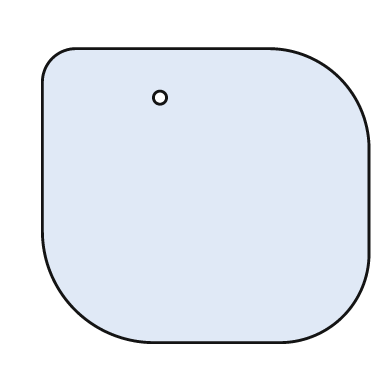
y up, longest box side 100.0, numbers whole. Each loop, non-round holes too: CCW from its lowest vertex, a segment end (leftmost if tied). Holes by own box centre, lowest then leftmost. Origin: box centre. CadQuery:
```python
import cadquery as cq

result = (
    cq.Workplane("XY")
    .moveTo(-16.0, -45.0)
    .lineTo(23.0, -45.0)
    .threePointArc((42.0, -37.0), (50.0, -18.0))
    .lineTo(50.0, 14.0)
    .threePointArc((41.0, 36.0), (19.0, 45.0))
    .lineTo(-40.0, 45.0)
    .threePointArc((-47.0, 42.0), (-50.0, 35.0))
    .lineTo(-50.0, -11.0)
    .threePointArc((-40.0, -35.0), (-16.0, -45.0))
    .close()
    .moveTo(-14.0, 30.0)
    .circle(2.0)
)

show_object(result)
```